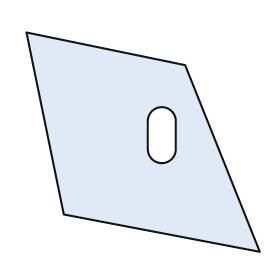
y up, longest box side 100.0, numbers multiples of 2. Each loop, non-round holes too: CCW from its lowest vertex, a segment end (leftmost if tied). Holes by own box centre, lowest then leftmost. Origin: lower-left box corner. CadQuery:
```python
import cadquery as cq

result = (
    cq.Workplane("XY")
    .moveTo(100.0, 0.0)
    .lineTo(68.0, 80.0)
    .lineTo(0.0, 94.0)
    .lineTo(16.0, 16.0)
    .close()
    .moveTo(52.0, 44.0)
    .threePointArc((58.0, 38.0), (64.0, 44.0))
    .lineTo(64.0, 56.0)
    .threePointArc((58.0, 62.0), (52.0, 56.0))
    .close()
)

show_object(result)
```